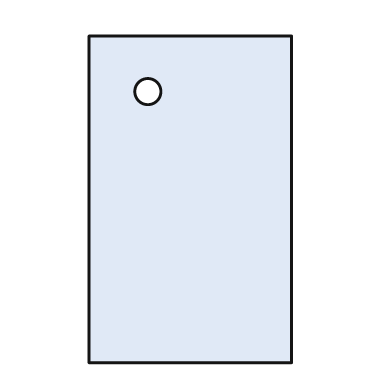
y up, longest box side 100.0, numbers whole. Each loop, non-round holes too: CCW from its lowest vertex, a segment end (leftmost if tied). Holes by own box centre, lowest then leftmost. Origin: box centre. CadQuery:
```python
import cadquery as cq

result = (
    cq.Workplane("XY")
    .moveTo(-31.0, -50.0)
    .lineTo(31.0, -50.0)
    .lineTo(31.0, 50.0)
    .lineTo(-31.0, 50.0)
    .close()
    .moveTo(-13.0, 33.0)
    .circle(4.0)
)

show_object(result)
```